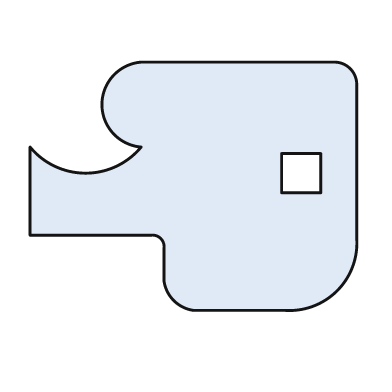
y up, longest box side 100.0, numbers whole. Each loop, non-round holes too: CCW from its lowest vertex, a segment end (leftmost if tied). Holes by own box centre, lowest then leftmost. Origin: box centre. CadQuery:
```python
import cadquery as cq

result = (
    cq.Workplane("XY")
    .moveTo(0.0, -38.0)
    .lineTo(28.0, -38.0)
    .threePointArc((44.0, -32.0), (50.0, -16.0))
    .lineTo(50.0, 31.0)
    .threePointArc((48.0, 36.0), (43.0, 38.0))
    .lineTo(-16.0, 38.0)
    .threePointArc((-28.0, 25.0), (-16.0, 12.0))
    .threePointArc((-33.0, 4.0), (-50.0, 12.0))
    .lineTo(-50.0, -15.0)
    .lineTo(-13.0, -15.0)
    .threePointArc((-10.0, -16.0), (-9.0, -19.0))
    .lineTo(-9.0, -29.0)
    .threePointArc((-6.0, -35.0), (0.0, -38.0))
    .close()
    .moveTo(27.0, -2.0)
    .lineTo(39.0, -2.0)
    .lineTo(39.0, 10.0)
    .lineTo(27.0, 10.0)
    .close()
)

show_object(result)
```